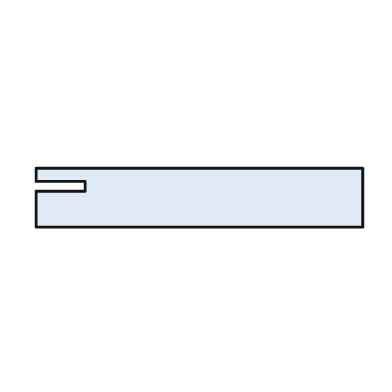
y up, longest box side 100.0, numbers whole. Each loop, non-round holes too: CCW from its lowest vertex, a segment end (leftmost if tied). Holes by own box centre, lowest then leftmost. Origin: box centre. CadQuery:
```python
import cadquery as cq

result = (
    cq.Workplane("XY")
    .moveTo(-50.0, -9.0)
    .lineTo(50.0, -9.0)
    .lineTo(50.0, 9.0)
    .lineTo(-50.0, 9.0)
    .lineTo(-50.0, 5.0)
    .lineTo(-35.0, 5.0)
    .lineTo(-35.0, 2.0)
    .lineTo(-50.0, 2.0)
    .close()
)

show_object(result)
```